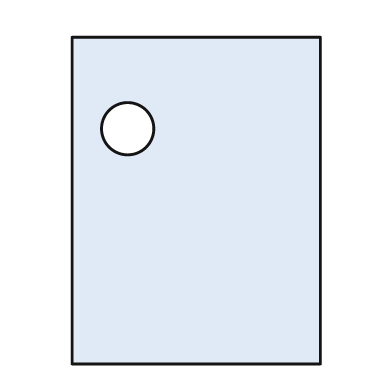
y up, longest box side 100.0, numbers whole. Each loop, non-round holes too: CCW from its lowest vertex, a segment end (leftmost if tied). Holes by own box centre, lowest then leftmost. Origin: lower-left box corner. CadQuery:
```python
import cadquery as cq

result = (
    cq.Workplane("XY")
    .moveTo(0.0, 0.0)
    .lineTo(76.0, 0.0)
    .lineTo(76.0, 100.0)
    .lineTo(0.0, 100.0)
    .close()
    .moveTo(17.0, 72.0)
    .circle(8.0)
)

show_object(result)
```